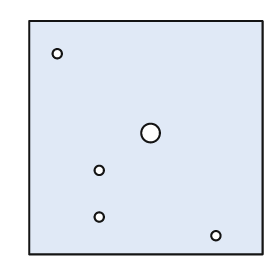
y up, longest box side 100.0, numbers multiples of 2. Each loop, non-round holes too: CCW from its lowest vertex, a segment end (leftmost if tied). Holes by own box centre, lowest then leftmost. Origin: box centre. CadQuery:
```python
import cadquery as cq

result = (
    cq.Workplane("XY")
    .moveTo(-50.0, -50.0)
    .lineTo(50.0, -50.0)
    .lineTo(50.0, 50.0)
    .lineTo(-50.0, 50.0)
    .close()
    .moveTo(30.0, -42.0)
    .circle(2.0)
    .moveTo(-20.0, -34.0)
    .circle(2.0)
    .moveTo(-20.0, -14.0)
    .circle(2.0)
    .moveTo(2.0, 2.0)
    .circle(4.0)
    .moveTo(-38.0, 36.0)
    .circle(2.0)
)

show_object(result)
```